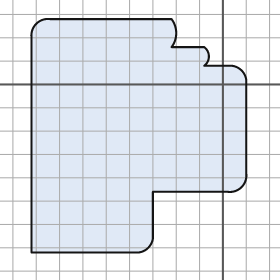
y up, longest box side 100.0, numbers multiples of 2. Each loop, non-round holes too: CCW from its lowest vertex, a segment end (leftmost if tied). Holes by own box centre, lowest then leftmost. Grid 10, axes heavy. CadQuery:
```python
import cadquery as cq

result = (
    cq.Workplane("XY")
    .moveTo(-82.0, -72.0)
    .lineTo(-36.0, -72.0)
    .threePointArc((-32.0, -70.0), (-30.0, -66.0))
    .lineTo(-30.0, -46.0)
    .lineTo(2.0, -46.0)
    .threePointArc((8.0, -44.0), (10.0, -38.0))
    .lineTo(10.0, 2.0)
    .threePointArc((8.0, 6.0), (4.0, 8.0))
    .lineTo(-8.0, 8.0)
    .threePointArc((-6.0, 12.0), (-8.0, 16.0))
    .lineTo(-22.0, 16.0)
    .threePointArc((-20.0, 22.0), (-22.0, 28.0))
    .lineTo(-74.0, 28.0)
    .threePointArc((-80.0, 26.0), (-82.0, 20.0))
    .close()
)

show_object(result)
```